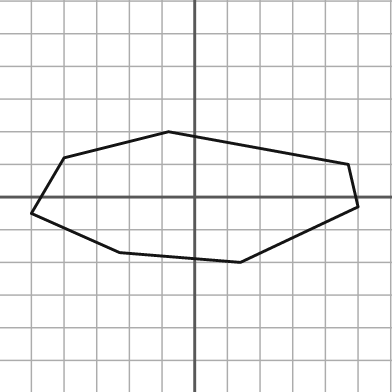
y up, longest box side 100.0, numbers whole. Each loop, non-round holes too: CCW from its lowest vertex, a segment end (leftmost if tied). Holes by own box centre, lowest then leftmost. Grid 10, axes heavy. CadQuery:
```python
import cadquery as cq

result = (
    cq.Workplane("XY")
    .moveTo(14.0, -20.0)
    .lineTo(50.0, -3.0)
    .lineTo(47.0, 10.0)
    .lineTo(-8.0, 20.0)
    .lineTo(-40.0, 12.0)
    .lineTo(-50.0, -5.0)
    .lineTo(-23.0, -17.0)
    .close()
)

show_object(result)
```